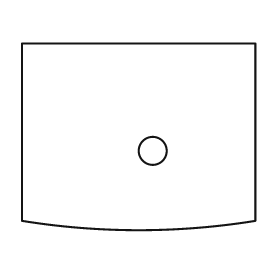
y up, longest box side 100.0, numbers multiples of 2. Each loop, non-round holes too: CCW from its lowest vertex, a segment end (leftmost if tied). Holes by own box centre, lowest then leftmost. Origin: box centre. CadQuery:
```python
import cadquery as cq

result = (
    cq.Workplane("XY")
    .moveTo(-50.0, -36.0)
    .threePointArc((0.0, -40.0), (50.0, -36.0))
    .lineTo(50.0, 40.0)
    .lineTo(-50.0, 40.0)
    .close()
    .moveTo(6.0, -6.0)
    .circle(6.0)
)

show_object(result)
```